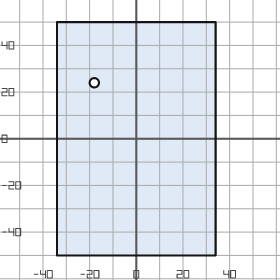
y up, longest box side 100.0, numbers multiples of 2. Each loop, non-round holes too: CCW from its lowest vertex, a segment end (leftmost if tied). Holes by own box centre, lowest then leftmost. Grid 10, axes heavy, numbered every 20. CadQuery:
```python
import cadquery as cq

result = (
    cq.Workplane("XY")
    .moveTo(-34.0, -50.0)
    .lineTo(34.0, -50.0)
    .lineTo(34.0, 50.0)
    .lineTo(-34.0, 50.0)
    .close()
    .moveTo(-18.0, 24.0)
    .circle(2.0)
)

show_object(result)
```